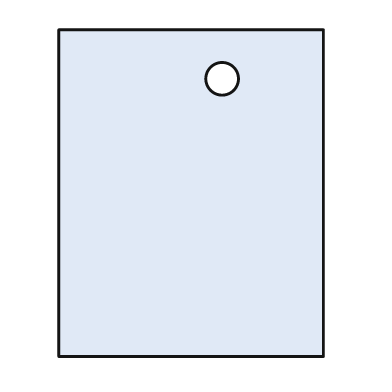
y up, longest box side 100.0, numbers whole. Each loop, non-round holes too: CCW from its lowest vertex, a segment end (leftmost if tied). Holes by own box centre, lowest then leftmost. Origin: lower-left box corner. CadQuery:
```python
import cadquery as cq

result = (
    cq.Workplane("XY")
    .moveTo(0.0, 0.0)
    .lineTo(81.0, 0.0)
    .lineTo(81.0, 100.0)
    .lineTo(0.0, 100.0)
    .close()
    .moveTo(50.0, 85.0)
    .circle(5.0)
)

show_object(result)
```